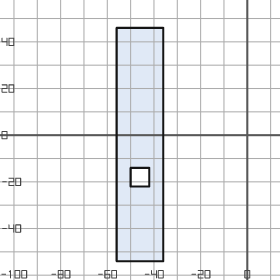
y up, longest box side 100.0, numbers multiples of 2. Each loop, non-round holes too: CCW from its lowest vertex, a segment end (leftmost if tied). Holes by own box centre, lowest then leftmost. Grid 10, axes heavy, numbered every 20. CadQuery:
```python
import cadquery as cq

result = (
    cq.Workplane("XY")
    .moveTo(-56.0, -54.0)
    .lineTo(-36.0, -54.0)
    .lineTo(-36.0, 46.0)
    .lineTo(-56.0, 46.0)
    .close()
    .moveTo(-50.0, -22.0)
    .lineTo(-42.0, -22.0)
    .lineTo(-42.0, -14.0)
    .lineTo(-50.0, -14.0)
    .close()
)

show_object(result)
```